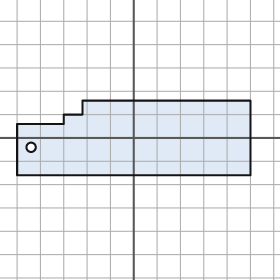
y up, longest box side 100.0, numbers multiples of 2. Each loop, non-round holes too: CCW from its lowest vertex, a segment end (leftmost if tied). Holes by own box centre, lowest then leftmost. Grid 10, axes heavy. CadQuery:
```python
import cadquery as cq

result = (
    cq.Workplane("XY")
    .moveTo(-50.0, -16.0)
    .lineTo(50.0, -16.0)
    .lineTo(50.0, 16.0)
    .lineTo(-22.0, 16.0)
    .lineTo(-22.0, 10.0)
    .lineTo(-30.0, 10.0)
    .lineTo(-30.0, 6.0)
    .lineTo(-50.0, 6.0)
    .close()
    .moveTo(-44.0, -4.0)
    .circle(2.0)
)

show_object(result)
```